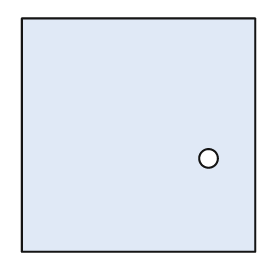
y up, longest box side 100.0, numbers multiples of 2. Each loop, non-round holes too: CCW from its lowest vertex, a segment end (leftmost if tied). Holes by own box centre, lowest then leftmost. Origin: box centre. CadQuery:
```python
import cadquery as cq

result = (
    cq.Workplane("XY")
    .moveTo(-50.0, -50.0)
    .lineTo(50.0, -50.0)
    .lineTo(50.0, 50.0)
    .lineTo(-50.0, 50.0)
    .close()
    .moveTo(30.0, -10.0)
    .circle(4.0)
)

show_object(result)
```